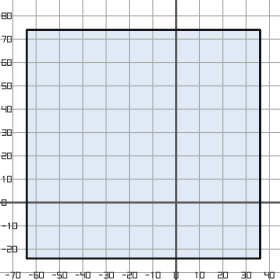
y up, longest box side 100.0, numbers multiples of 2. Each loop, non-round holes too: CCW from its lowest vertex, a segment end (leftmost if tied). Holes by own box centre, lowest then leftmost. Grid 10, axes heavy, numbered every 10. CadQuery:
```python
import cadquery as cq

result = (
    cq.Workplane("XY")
    .moveTo(-64.0, -24.0)
    .lineTo(36.0, -24.0)
    .lineTo(36.0, 74.0)
    .lineTo(-64.0, 74.0)
    .close()
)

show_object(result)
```